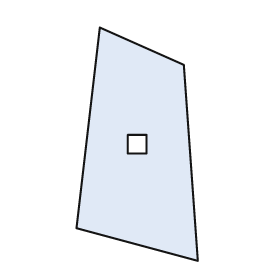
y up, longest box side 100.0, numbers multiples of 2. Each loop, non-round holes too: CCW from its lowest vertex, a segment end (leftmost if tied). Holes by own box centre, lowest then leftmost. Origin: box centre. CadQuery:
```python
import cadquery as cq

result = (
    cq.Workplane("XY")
    .moveTo(26.0, -50.0)
    .lineTo(20.0, 34.0)
    .lineTo(-16.0, 50.0)
    .lineTo(-26.0, -36.0)
    .close()
    .moveTo(-4.0, -4.0)
    .lineTo(4.0, -4.0)
    .lineTo(4.0, 4.0)
    .lineTo(-4.0, 4.0)
    .close()
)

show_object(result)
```